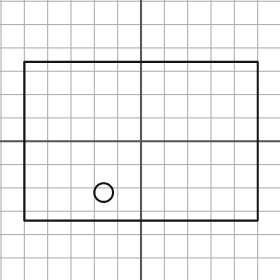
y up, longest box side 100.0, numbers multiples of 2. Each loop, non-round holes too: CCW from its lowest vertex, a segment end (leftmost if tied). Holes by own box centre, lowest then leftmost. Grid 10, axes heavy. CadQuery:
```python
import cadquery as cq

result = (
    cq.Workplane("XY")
    .moveTo(-50.0, -34.0)
    .lineTo(50.0, -34.0)
    .lineTo(50.0, 34.0)
    .lineTo(-50.0, 34.0)
    .close()
    .moveTo(-16.0, -22.0)
    .circle(4.0)
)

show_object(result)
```